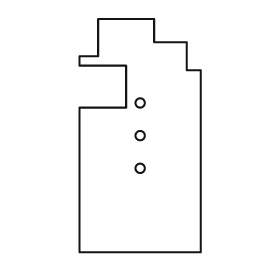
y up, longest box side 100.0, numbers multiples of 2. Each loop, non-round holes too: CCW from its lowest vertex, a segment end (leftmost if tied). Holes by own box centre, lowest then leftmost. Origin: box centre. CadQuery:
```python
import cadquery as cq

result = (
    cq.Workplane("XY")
    .moveTo(-26.0, -50.0)
    .lineTo(26.0, -50.0)
    .lineTo(26.0, 28.0)
    .lineTo(20.0, 28.0)
    .lineTo(20.0, 40.0)
    .lineTo(6.0, 40.0)
    .lineTo(6.0, 50.0)
    .lineTo(-18.0, 50.0)
    .lineTo(-18.0, 34.0)
    .lineTo(-26.0, 34.0)
    .lineTo(-26.0, 30.0)
    .lineTo(-6.0, 30.0)
    .lineTo(-6.0, 12.0)
    .lineTo(-26.0, 12.0)
    .close()
    .moveTo(0.0, -14.0)
    .circle(2.0)
    .moveTo(0.0, 0.0)
    .circle(2.0)
    .moveTo(0.0, 14.0)
    .circle(2.0)
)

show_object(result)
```